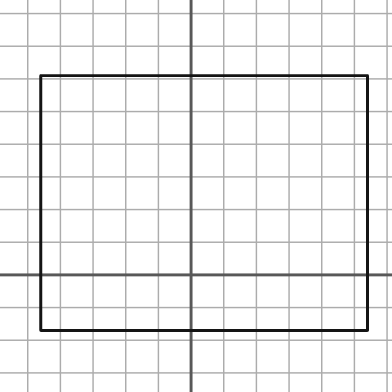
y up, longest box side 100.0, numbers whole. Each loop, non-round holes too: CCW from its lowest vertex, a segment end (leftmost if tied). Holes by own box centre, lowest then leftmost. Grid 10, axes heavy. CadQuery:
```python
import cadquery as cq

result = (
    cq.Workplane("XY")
    .moveTo(-46.0, -17.0)
    .lineTo(54.0, -17.0)
    .lineTo(54.0, 61.0)
    .lineTo(-46.0, 61.0)
    .close()
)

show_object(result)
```